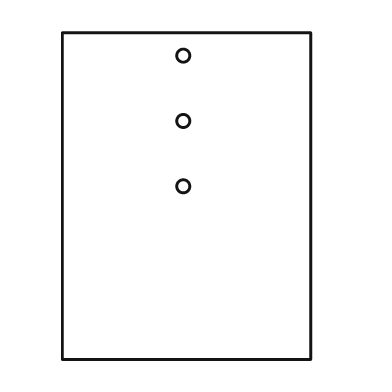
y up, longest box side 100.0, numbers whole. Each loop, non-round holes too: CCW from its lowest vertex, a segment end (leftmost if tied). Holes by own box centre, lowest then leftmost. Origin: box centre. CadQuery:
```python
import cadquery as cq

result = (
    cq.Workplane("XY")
    .moveTo(-38.0, -50.0)
    .lineTo(38.0, -50.0)
    .lineTo(38.0, 50.0)
    .lineTo(-38.0, 50.0)
    .close()
    .moveTo(-1.0, 3.0)
    .circle(2.0)
    .moveTo(-1.0, 23.0)
    .circle(2.0)
    .moveTo(-1.0, 43.0)
    .circle(2.0)
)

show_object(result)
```